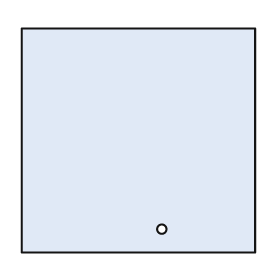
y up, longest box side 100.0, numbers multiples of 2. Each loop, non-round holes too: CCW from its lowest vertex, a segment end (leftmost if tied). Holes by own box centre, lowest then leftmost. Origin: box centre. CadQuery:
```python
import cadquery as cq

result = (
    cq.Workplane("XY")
    .moveTo(-50.0, -48.0)
    .lineTo(50.0, -48.0)
    .lineTo(50.0, 48.0)
    .lineTo(-50.0, 48.0)
    .close()
    .moveTo(10.0, -38.0)
    .circle(2.0)
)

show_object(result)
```